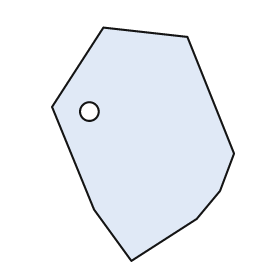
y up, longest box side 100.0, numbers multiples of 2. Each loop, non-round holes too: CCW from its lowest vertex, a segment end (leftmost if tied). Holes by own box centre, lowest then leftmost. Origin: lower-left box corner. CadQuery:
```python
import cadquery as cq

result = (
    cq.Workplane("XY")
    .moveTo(34.0, 0.0)
    .lineTo(62.0, 18.0)
    .lineTo(72.0, 30.0)
    .lineTo(78.0, 46.0)
    .lineTo(58.0, 96.0)
    .lineTo(22.0, 100.0)
    .lineTo(0.0, 66.0)
    .lineTo(18.0, 22.0)
    .close()
    .moveTo(16.0, 64.0)
    .circle(4.0)
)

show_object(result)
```